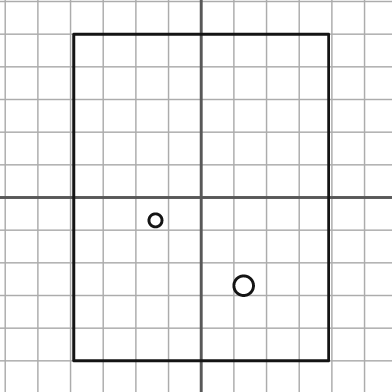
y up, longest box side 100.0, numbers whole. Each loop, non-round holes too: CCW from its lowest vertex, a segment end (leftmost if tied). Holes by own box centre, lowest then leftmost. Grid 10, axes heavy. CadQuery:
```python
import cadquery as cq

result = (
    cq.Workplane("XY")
    .moveTo(-39.0, -50.0)
    .lineTo(39.0, -50.0)
    .lineTo(39.0, 50.0)
    .lineTo(-39.0, 50.0)
    .close()
    .moveTo(13.0, -27.0)
    .circle(3.0)
    .moveTo(-14.0, -7.0)
    .circle(2.0)
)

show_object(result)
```